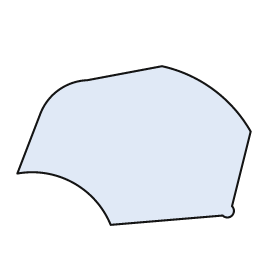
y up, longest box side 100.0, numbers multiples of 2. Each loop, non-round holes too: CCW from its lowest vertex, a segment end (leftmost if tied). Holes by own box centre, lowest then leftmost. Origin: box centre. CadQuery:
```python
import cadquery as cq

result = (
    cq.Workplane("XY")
    .moveTo(-10.0, -34.0)
    .lineTo(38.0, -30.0)
    .threePointArc((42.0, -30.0), (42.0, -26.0))
    .lineTo(50.0, 6.0)
    .threePointArc((34.0, 24.0), (12.0, 34.0))
    .lineTo(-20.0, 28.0)
    .threePointArc((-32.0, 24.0), (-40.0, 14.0))
    .lineTo(-50.0, -12.0)
    .threePointArc((-26.0, -16.0), (-10.0, -34.0))
    .close()
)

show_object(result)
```